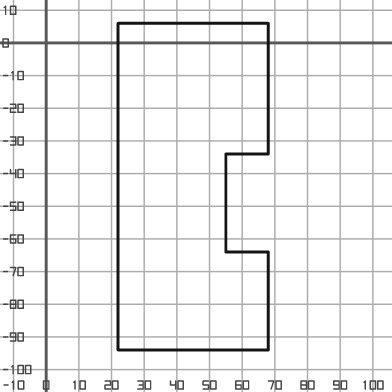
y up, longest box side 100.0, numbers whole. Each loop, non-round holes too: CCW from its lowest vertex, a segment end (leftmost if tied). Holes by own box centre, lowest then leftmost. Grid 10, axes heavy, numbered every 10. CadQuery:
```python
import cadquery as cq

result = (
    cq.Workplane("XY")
    .moveTo(22.0, -94.0)
    .lineTo(68.0, -94.0)
    .lineTo(68.0, -64.0)
    .lineTo(55.0, -64.0)
    .lineTo(55.0, -34.0)
    .lineTo(68.0, -34.0)
    .lineTo(68.0, 6.0)
    .lineTo(22.0, 6.0)
    .close()
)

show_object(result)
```